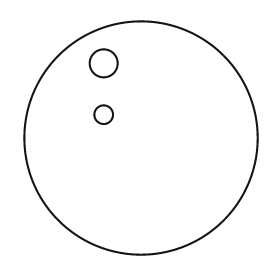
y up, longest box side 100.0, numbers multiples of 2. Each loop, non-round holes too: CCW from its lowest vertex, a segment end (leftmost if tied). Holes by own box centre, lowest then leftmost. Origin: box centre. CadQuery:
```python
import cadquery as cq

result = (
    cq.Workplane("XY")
    .moveTo(0.0, 0.0)
    .circle(50.0)
    .moveTo(-16.0, 10.0)
    .circle(4.0)
    .moveTo(-16.0, 32.0)
    .circle(6.0)
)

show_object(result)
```